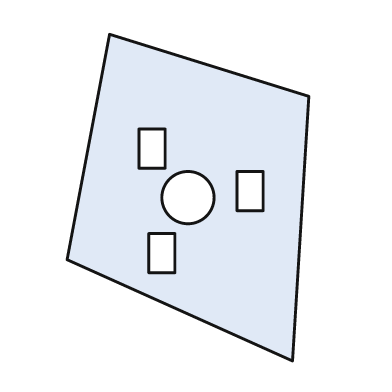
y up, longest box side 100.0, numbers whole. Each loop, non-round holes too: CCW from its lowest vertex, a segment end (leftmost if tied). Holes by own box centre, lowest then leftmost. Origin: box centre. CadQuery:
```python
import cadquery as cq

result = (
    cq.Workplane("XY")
    .moveTo(32.0, -50.0)
    .lineTo(37.0, 31.0)
    .lineTo(-24.0, 50.0)
    .lineTo(-37.0, -19.0)
    .close()
    .moveTo(-12.0, -23.0)
    .lineTo(-4.0, -23.0)
    .lineTo(-4.0, -11.0)
    .lineTo(-12.0, -11.0)
    .close()
    .moveTo(0.0, 0.0)
    .circle(8.0)
    .moveTo(15.0, -4.0)
    .lineTo(23.0, -4.0)
    .lineTo(23.0, 8.0)
    .lineTo(15.0, 8.0)
    .close()
    .moveTo(-15.0, 9.0)
    .lineTo(-7.0, 9.0)
    .lineTo(-7.0, 21.0)
    .lineTo(-15.0, 21.0)
    .close()
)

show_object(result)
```